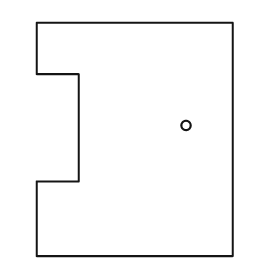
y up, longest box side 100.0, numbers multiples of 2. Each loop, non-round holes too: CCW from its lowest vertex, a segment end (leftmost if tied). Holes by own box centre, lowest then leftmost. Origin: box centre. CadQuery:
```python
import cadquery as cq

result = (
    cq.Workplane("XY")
    .moveTo(-42.0, -50.0)
    .lineTo(42.0, -50.0)
    .lineTo(42.0, 50.0)
    .lineTo(-42.0, 50.0)
    .lineTo(-42.0, 28.0)
    .lineTo(-24.0, 28.0)
    .lineTo(-24.0, -18.0)
    .lineTo(-42.0, -18.0)
    .close()
    .moveTo(22.0, 6.0)
    .circle(2.0)
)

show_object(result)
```